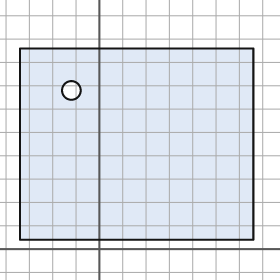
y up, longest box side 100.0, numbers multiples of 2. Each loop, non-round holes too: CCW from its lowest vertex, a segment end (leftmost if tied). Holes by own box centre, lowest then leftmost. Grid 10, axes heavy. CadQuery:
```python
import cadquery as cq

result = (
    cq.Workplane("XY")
    .moveTo(-34.0, 4.0)
    .lineTo(66.0, 4.0)
    .lineTo(66.0, 86.0)
    .lineTo(-34.0, 86.0)
    .close()
    .moveTo(-12.0, 68.0)
    .circle(4.0)
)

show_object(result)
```